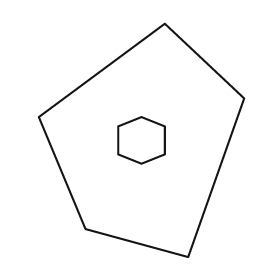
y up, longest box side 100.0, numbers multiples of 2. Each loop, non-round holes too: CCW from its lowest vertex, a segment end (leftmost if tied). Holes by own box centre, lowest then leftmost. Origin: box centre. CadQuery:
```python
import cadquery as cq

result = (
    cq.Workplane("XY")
    .moveTo(20.0, -50.0)
    .lineTo(44.0, 18.0)
    .lineTo(10.0, 50.0)
    .lineTo(-44.0, 10.0)
    .lineTo(-24.0, -38.0)
    .close()
    .moveTo(0.0, -10.0)
    .lineTo(10.0, -6.0)
    .lineTo(10.0, 6.0)
    .lineTo(0.0, 10.0)
    .lineTo(-10.0, 6.0)
    .lineTo(-10.0, -6.0)
    .close()
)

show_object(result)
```